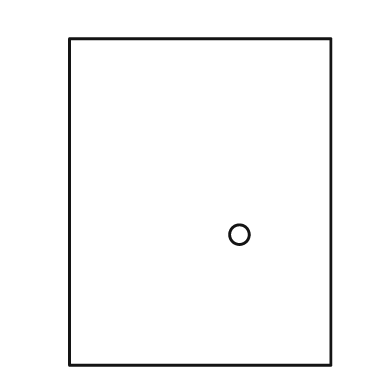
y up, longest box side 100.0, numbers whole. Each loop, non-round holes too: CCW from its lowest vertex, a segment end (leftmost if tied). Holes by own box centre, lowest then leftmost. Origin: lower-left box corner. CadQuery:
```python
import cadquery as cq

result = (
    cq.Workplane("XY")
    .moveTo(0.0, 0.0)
    .lineTo(80.0, 0.0)
    .lineTo(80.0, 100.0)
    .lineTo(0.0, 100.0)
    .close()
    .moveTo(52.0, 40.0)
    .circle(3.0)
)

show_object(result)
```